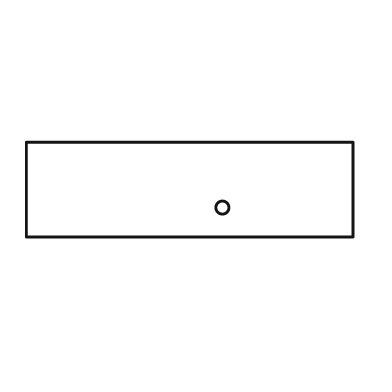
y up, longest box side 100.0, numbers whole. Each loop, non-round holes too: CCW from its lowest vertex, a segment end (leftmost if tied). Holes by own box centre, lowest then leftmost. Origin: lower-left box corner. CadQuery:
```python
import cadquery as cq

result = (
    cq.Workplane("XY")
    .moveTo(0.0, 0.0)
    .lineTo(100.0, 0.0)
    .lineTo(100.0, 29.0)
    .lineTo(0.0, 29.0)
    .close()
    .moveTo(60.0, 9.0)
    .circle(2.0)
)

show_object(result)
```